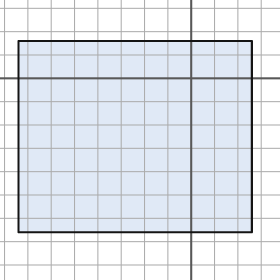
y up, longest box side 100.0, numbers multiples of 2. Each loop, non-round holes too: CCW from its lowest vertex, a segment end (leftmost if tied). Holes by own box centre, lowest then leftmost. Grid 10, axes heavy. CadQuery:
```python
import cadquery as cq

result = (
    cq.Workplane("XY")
    .moveTo(-74.0, -66.0)
    .lineTo(26.0, -66.0)
    .lineTo(26.0, 16.0)
    .lineTo(-74.0, 16.0)
    .close()
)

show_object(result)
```